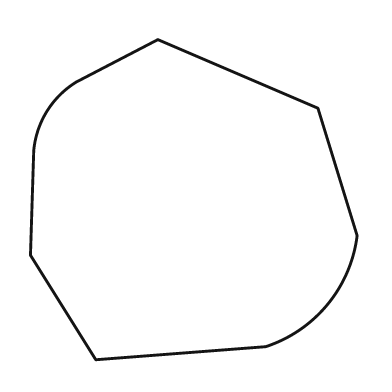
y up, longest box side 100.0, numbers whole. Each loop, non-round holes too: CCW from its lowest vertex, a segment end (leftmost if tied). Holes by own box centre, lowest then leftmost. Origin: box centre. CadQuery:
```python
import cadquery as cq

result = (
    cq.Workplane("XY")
    .moveTo(-30.0, -49.0)
    .lineTo(22.0, -45.0)
    .threePointArc((41.0, -32.0), (50.0, -11.0))
    .lineTo(38.0, 28.0)
    .lineTo(-11.0, 49.0)
    .lineTo(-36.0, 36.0)
    .threePointArc((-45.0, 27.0), (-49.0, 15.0))
    .lineTo(-50.0, -17.0)
    .close()
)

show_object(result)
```